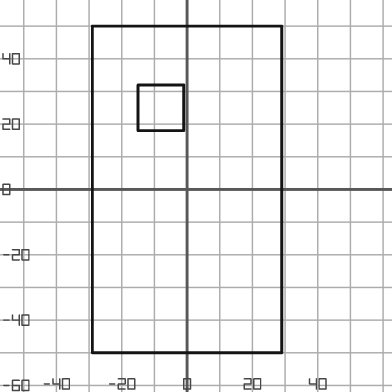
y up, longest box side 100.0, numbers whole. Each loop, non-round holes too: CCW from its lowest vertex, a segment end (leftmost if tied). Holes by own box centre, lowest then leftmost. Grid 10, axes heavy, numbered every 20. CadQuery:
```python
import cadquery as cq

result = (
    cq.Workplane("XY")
    .moveTo(-29.0, -50.0)
    .lineTo(29.0, -50.0)
    .lineTo(29.0, 50.0)
    .lineTo(-29.0, 50.0)
    .close()
    .moveTo(-15.0, 18.0)
    .lineTo(-1.0, 18.0)
    .lineTo(-1.0, 32.0)
    .lineTo(-15.0, 32.0)
    .close()
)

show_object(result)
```